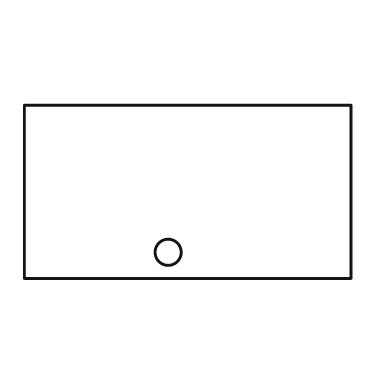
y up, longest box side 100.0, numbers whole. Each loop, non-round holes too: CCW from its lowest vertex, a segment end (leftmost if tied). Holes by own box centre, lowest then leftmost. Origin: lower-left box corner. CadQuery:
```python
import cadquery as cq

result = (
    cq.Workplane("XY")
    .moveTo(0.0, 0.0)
    .lineTo(100.0, 0.0)
    .lineTo(100.0, 53.0)
    .lineTo(0.0, 53.0)
    .close()
    .moveTo(44.0, 8.0)
    .circle(4.0)
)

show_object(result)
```